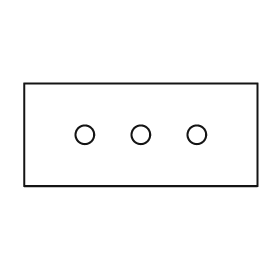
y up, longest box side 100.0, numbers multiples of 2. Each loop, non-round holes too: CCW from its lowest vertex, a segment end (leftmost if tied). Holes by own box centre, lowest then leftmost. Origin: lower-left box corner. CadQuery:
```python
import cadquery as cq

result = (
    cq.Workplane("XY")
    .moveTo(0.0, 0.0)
    .lineTo(100.0, 0.0)
    .lineTo(100.0, 44.0)
    .lineTo(0.0, 44.0)
    .close()
    .moveTo(26.0, 22.0)
    .circle(4.0)
    .moveTo(50.0, 22.0)
    .circle(4.0)
    .moveTo(74.0, 22.0)
    .circle(4.0)
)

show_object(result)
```